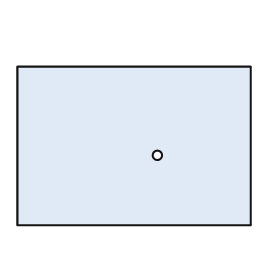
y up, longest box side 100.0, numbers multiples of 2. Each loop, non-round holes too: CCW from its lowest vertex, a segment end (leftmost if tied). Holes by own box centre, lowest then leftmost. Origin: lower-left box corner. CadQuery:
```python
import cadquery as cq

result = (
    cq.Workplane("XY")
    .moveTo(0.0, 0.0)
    .lineTo(100.0, 0.0)
    .lineTo(100.0, 68.0)
    .lineTo(0.0, 68.0)
    .close()
    .moveTo(60.0, 30.0)
    .circle(2.0)
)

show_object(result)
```